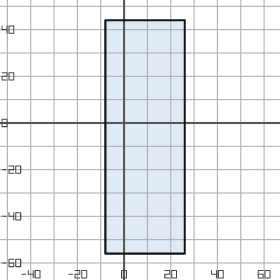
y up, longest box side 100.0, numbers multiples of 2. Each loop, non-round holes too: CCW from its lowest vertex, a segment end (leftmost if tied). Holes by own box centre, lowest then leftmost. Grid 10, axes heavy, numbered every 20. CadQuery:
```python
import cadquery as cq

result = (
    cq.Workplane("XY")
    .moveTo(-8.0, -56.0)
    .lineTo(26.0, -56.0)
    .lineTo(26.0, 44.0)
    .lineTo(-8.0, 44.0)
    .close()
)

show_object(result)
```